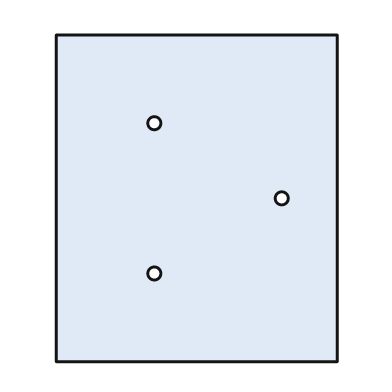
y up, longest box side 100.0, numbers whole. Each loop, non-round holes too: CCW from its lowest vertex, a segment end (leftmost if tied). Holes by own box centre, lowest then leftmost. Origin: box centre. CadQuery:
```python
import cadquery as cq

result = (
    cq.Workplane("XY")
    .moveTo(-43.0, -50.0)
    .lineTo(43.0, -50.0)
    .lineTo(43.0, 50.0)
    .lineTo(-43.0, 50.0)
    .close()
    .moveTo(-13.0, -23.0)
    .circle(2.0)
    .moveTo(26.0, 0.0)
    .circle(2.0)
    .moveTo(-13.0, 23.0)
    .circle(2.0)
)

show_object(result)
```